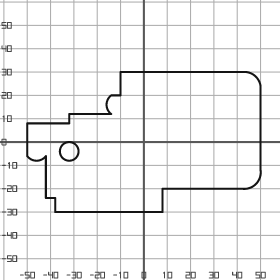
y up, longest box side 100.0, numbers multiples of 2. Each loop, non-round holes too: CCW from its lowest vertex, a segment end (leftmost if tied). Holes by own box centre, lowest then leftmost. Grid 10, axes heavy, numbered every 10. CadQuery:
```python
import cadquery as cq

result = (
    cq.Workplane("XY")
    .moveTo(-38.0, -30.0)
    .lineTo(8.0, -30.0)
    .lineTo(8.0, -20.0)
    .lineTo(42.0, -20.0)
    .threePointArc((48.0, -18.0), (50.0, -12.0))
    .lineTo(50.0, 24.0)
    .threePointArc((48.0, 28.0), (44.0, 30.0))
    .lineTo(-10.0, 30.0)
    .lineTo(-10.0, 20.0)
    .lineTo(-14.0, 20.0)
    .threePointArc((-16.0, 16.0), (-14.0, 12.0))
    .lineTo(-32.0, 12.0)
    .lineTo(-32.0, 8.0)
    .lineTo(-50.0, 8.0)
    .lineTo(-50.0, -6.0)
    .threePointArc((-46.0, -8.0), (-42.0, -6.0))
    .lineTo(-42.0, -24.0)
    .lineTo(-38.0, -24.0)
    .close()
    .moveTo(-32.0, -4.0)
    .circle(4.0)
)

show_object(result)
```